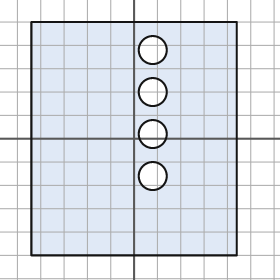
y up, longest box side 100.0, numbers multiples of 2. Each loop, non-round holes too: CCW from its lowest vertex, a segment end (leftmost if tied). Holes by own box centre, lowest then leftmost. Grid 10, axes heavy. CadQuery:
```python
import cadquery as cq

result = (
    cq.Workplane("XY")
    .moveTo(-44.0, -50.0)
    .lineTo(44.0, -50.0)
    .lineTo(44.0, 50.0)
    .lineTo(-44.0, 50.0)
    .close()
    .moveTo(8.0, -16.0)
    .circle(6.0)
    .moveTo(8.0, 2.0)
    .circle(6.0)
    .moveTo(8.0, 20.0)
    .circle(6.0)
    .moveTo(8.0, 38.0)
    .circle(6.0)
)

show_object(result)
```